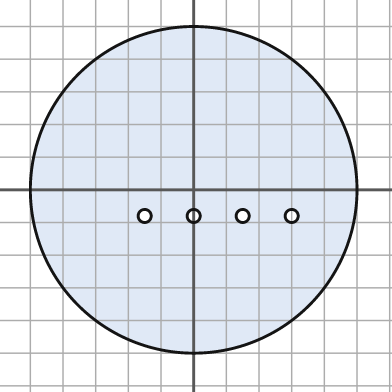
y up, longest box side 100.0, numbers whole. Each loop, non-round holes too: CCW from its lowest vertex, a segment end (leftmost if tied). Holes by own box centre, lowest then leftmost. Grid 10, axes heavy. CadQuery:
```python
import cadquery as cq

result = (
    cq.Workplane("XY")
    .moveTo(0.0, 0.0)
    .circle(50.0)
    .moveTo(-15.0, -8.0)
    .circle(2.0)
    .moveTo(0.0, -8.0)
    .circle(2.0)
    .moveTo(15.0, -8.0)
    .circle(2.0)
    .moveTo(30.0, -8.0)
    .circle(2.0)
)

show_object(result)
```